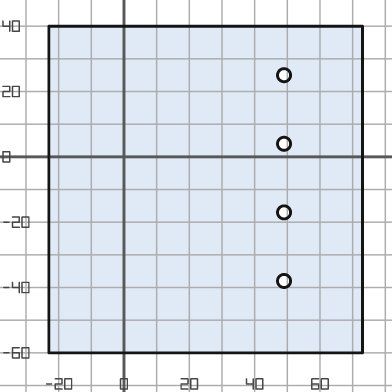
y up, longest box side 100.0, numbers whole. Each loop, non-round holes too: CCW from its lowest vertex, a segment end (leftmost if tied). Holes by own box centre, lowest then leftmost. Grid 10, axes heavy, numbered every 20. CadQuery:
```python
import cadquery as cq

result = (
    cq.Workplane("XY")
    .moveTo(-23.0, -60.0)
    .lineTo(73.0, -60.0)
    .lineTo(73.0, 40.0)
    .lineTo(-23.0, 40.0)
    .close()
    .moveTo(49.0, -38.0)
    .circle(2.0)
    .moveTo(49.0, -17.0)
    .circle(2.0)
    .moveTo(49.0, 4.0)
    .circle(2.0)
    .moveTo(49.0, 25.0)
    .circle(2.0)
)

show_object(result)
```